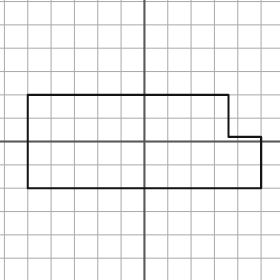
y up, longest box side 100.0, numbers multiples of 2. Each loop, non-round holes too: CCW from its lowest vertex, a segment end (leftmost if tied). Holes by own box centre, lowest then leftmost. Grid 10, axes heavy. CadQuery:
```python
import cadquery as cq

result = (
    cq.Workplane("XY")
    .moveTo(-50.0, -20.0)
    .lineTo(50.0, -20.0)
    .lineTo(50.0, 2.0)
    .lineTo(36.0, 2.0)
    .lineTo(36.0, 20.0)
    .lineTo(-50.0, 20.0)
    .close()
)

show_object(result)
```